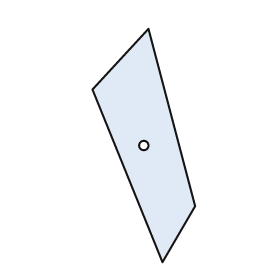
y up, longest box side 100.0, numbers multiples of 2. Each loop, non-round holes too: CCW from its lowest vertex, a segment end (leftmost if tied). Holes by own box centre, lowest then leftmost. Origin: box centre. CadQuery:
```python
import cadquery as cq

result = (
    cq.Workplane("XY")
    .moveTo(8.0, -50.0)
    .lineTo(22.0, -26.0)
    .lineTo(2.0, 50.0)
    .lineTo(-22.0, 24.0)
    .close()
    .moveTo(0.0, 0.0)
    .circle(2.0)
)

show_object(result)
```